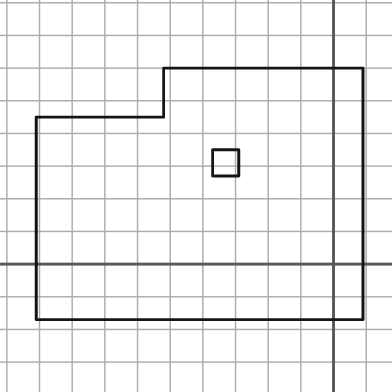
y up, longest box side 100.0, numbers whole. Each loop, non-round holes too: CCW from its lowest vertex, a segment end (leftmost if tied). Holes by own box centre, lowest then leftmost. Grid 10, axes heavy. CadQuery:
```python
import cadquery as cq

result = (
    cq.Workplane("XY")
    .moveTo(-91.0, -17.0)
    .lineTo(9.0, -17.0)
    .lineTo(9.0, 60.0)
    .lineTo(-52.0, 60.0)
    .lineTo(-52.0, 45.0)
    .lineTo(-91.0, 45.0)
    .close()
    .moveTo(-37.0, 27.0)
    .lineTo(-29.0, 27.0)
    .lineTo(-29.0, 35.0)
    .lineTo(-37.0, 35.0)
    .close()
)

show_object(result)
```